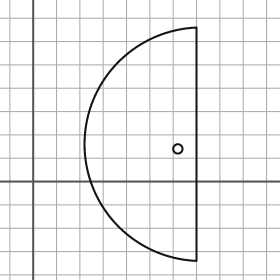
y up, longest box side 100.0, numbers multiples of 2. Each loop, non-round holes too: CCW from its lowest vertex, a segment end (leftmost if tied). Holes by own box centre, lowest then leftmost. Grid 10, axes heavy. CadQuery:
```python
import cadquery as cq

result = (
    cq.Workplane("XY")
    .moveTo(70.0, -34.0)
    .lineTo(70.0, 66.0)
    .threePointArc((22.0, 16.0), (70.0, -34.0))
    .close()
    .moveTo(62.0, 14.0)
    .circle(2.0)
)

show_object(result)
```